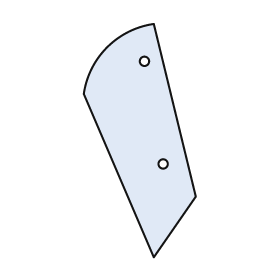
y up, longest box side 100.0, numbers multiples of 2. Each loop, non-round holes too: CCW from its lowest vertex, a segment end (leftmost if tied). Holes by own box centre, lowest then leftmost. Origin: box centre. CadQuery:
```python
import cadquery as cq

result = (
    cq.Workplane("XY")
    .moveTo(6.0, -50.0)
    .lineTo(24.0, -24.0)
    .lineTo(6.0, 50.0)
    .threePointArc((-14.0, 40.0), (-24.0, 20.0))
    .close()
    .moveTo(10.0, -10.0)
    .circle(2.0)
    .moveTo(2.0, 34.0)
    .circle(2.0)
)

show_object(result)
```